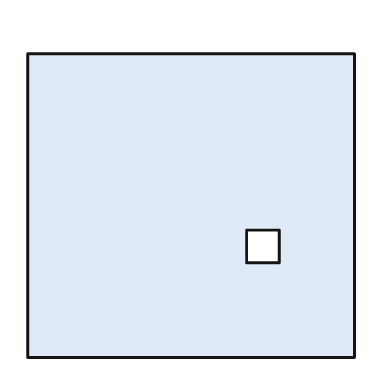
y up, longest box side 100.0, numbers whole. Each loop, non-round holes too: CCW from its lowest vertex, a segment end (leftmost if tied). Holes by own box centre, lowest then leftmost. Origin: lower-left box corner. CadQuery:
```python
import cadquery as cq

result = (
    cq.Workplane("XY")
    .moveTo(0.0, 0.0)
    .lineTo(100.0, 0.0)
    .lineTo(100.0, 93.0)
    .lineTo(0.0, 93.0)
    .close()
    .moveTo(67.0, 29.0)
    .lineTo(77.0, 29.0)
    .lineTo(77.0, 39.0)
    .lineTo(67.0, 39.0)
    .close()
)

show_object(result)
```